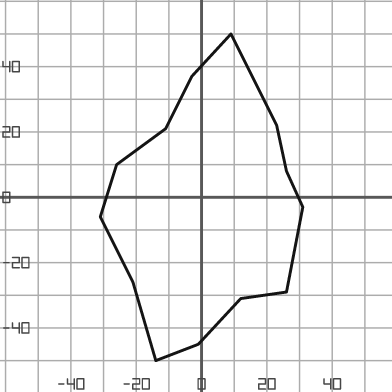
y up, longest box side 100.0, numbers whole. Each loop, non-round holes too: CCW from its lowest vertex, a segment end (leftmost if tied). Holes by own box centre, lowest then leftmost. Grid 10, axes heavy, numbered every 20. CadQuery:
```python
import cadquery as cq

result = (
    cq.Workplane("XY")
    .moveTo(-14.0, -50.0)
    .lineTo(-1.0, -45.0)
    .lineTo(12.0, -31.0)
    .lineTo(26.0, -29.0)
    .lineTo(31.0, -3.0)
    .lineTo(26.0, 8.0)
    .lineTo(23.0, 22.0)
    .lineTo(9.0, 50.0)
    .lineTo(-3.0, 37.0)
    .lineTo(-11.0, 21.0)
    .lineTo(-26.0, 10.0)
    .lineTo(-31.0, -6.0)
    .lineTo(-21.0, -26.0)
    .close()
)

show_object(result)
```